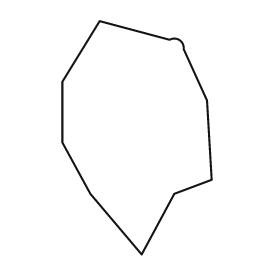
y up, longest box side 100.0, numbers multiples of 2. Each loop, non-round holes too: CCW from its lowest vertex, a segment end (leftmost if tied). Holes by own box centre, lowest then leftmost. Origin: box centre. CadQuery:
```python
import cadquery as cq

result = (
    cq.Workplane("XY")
    .moveTo(2.0, -50.0)
    .lineTo(16.0, -24.0)
    .lineTo(32.0, -18.0)
    .lineTo(30.0, 16.0)
    .lineTo(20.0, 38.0)
    .threePointArc((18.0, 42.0), (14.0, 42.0))
    .lineTo(-16.0, 50.0)
    .lineTo(-32.0, 24.0)
    .lineTo(-32.0, -2.0)
    .lineTo(-20.0, -24.0)
    .close()
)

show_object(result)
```